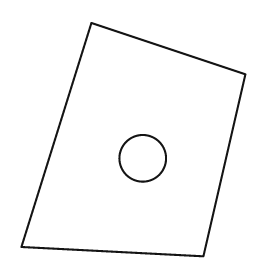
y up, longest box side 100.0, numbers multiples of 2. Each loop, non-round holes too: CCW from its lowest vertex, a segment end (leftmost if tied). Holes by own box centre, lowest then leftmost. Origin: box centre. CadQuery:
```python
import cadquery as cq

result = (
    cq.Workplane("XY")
    .moveTo(30.0, -50.0)
    .lineTo(48.0, 28.0)
    .lineTo(-18.0, 50.0)
    .lineTo(-48.0, -46.0)
    .close()
    .moveTo(4.0, -8.0)
    .circle(10.0)
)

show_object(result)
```